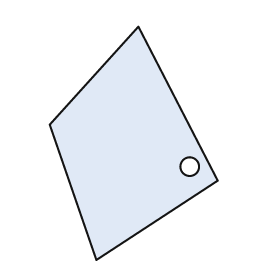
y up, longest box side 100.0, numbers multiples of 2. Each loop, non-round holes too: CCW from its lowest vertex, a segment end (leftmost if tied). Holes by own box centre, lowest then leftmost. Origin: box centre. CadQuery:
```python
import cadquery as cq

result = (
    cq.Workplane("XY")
    .moveTo(-16.0, -50.0)
    .lineTo(36.0, -16.0)
    .lineTo(2.0, 50.0)
    .lineTo(-36.0, 8.0)
    .close()
    .moveTo(24.0, -10.0)
    .circle(4.0)
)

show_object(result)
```